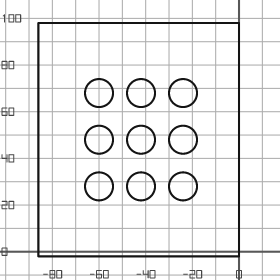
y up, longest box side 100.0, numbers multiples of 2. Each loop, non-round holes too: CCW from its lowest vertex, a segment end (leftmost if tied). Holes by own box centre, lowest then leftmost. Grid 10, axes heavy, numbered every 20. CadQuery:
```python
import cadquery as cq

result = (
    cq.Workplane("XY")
    .moveTo(-86.0, -2.0)
    .lineTo(0.0, -2.0)
    .lineTo(0.0, 98.0)
    .lineTo(-86.0, 98.0)
    .close()
    .moveTo(-60.0, 28.0)
    .circle(6.0)
    .moveTo(-42.0, 28.0)
    .circle(6.0)
    .moveTo(-24.0, 28.0)
    .circle(6.0)
    .moveTo(-60.0, 48.0)
    .circle(6.0)
    .moveTo(-42.0, 48.0)
    .circle(6.0)
    .moveTo(-24.0, 48.0)
    .circle(6.0)
    .moveTo(-60.0, 68.0)
    .circle(6.0)
    .moveTo(-42.0, 68.0)
    .circle(6.0)
    .moveTo(-24.0, 68.0)
    .circle(6.0)
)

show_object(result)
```